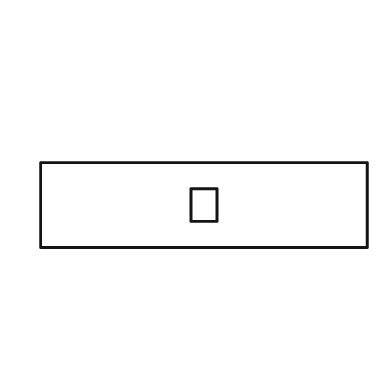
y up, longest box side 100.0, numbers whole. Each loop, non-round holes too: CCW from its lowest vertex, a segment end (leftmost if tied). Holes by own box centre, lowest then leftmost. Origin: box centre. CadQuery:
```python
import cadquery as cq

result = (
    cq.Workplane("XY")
    .moveTo(-50.0, -13.0)
    .lineTo(50.0, -13.0)
    .lineTo(50.0, 13.0)
    .lineTo(-50.0, 13.0)
    .close()
    .moveTo(-4.0, -5.0)
    .lineTo(4.0, -5.0)
    .lineTo(4.0, 5.0)
    .lineTo(-4.0, 5.0)
    .close()
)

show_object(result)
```